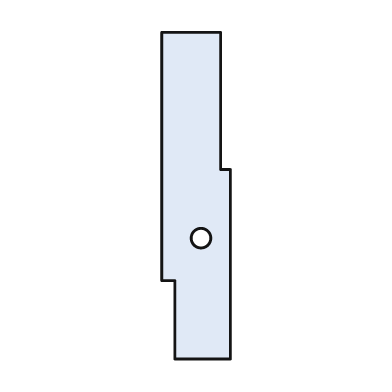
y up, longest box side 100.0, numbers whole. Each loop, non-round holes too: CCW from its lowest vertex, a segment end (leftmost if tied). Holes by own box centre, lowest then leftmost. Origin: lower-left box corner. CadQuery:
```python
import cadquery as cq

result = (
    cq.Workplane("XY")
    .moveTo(4.0, 0.0)
    .lineTo(21.0, 0.0)
    .lineTo(21.0, 58.0)
    .lineTo(18.0, 58.0)
    .lineTo(18.0, 100.0)
    .lineTo(0.0, 100.0)
    .lineTo(0.0, 24.0)
    .lineTo(4.0, 24.0)
    .close()
    .moveTo(12.0, 37.0)
    .circle(3.0)
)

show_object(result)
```